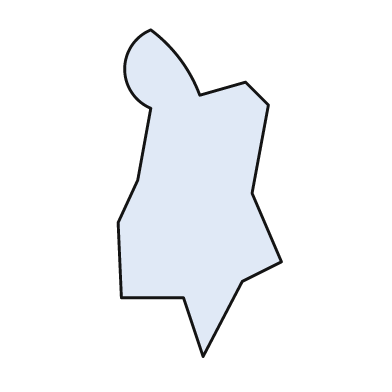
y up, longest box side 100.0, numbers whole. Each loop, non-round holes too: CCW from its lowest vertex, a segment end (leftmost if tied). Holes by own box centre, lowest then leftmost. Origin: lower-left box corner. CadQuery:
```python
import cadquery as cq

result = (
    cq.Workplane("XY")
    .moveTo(26.0, 0.0)
    .lineTo(38.0, 23.0)
    .lineTo(50.0, 29.0)
    .lineTo(41.0, 50.0)
    .lineTo(46.0, 77.0)
    .lineTo(39.0, 84.0)
    .lineTo(25.0, 80.0)
    .threePointArc((19.0, 91.0), (10.0, 100.0))
    .threePointArc((2.0, 88.0), (10.0, 76.0))
    .lineTo(6.0, 54.0)
    .lineTo(0.0, 41.0)
    .lineTo(1.0, 18.0)
    .lineTo(20.0, 18.0)
    .close()
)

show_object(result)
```